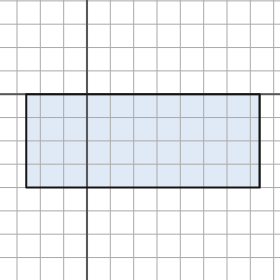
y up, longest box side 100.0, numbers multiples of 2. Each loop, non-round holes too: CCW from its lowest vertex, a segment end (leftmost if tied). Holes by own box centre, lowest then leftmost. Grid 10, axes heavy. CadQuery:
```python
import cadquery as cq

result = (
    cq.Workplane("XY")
    .moveTo(-26.0, -40.0)
    .lineTo(74.0, -40.0)
    .lineTo(74.0, 0.0)
    .lineTo(-26.0, 0.0)
    .close()
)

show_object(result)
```